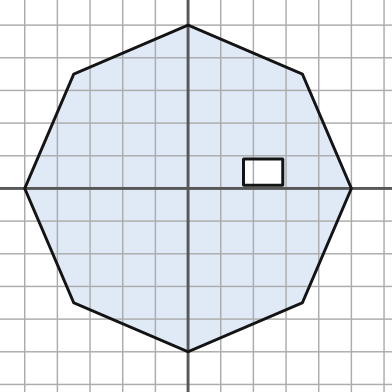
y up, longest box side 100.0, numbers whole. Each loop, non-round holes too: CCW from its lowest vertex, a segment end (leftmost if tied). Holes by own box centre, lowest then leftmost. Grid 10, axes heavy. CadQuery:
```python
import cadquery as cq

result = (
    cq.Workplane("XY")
    .moveTo(0.0, -50.0)
    .lineTo(35.0, -35.0)
    .lineTo(50.0, 0.0)
    .lineTo(35.0, 35.0)
    .lineTo(0.0, 50.0)
    .lineTo(-35.0, 35.0)
    .lineTo(-50.0, 0.0)
    .lineTo(-35.0, -35.0)
    .close()
    .moveTo(17.0, 1.0)
    .lineTo(29.0, 1.0)
    .lineTo(29.0, 9.0)
    .lineTo(17.0, 9.0)
    .close()
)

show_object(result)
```